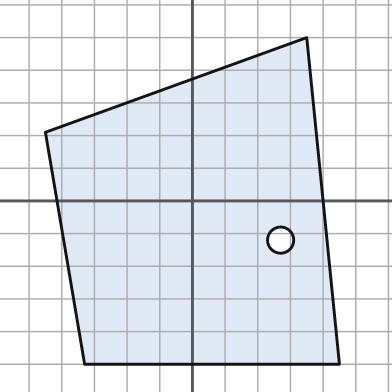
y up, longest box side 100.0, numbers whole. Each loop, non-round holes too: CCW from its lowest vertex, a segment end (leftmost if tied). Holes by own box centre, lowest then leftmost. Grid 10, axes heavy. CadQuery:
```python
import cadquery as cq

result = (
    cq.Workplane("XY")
    .moveTo(-33.0, -50.0)
    .lineTo(45.0, -50.0)
    .lineTo(35.0, 50.0)
    .lineTo(-45.0, 21.0)
    .close()
    .moveTo(27.0, -12.0)
    .circle(4.0)
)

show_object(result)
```